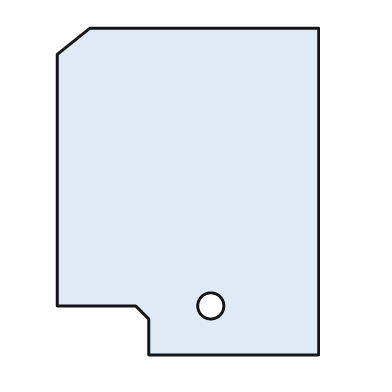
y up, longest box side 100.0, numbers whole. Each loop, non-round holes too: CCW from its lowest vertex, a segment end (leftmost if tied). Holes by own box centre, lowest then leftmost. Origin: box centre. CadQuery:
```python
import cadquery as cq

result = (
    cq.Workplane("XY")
    .moveTo(-12.0, -50.0)
    .lineTo(40.0, -50.0)
    .lineTo(40.0, 50.0)
    .lineTo(-30.0, 50.0)
    .lineTo(-40.0, 42.0)
    .lineTo(-40.0, -35.0)
    .lineTo(-16.0, -35.0)
    .lineTo(-12.0, -39.0)
    .close()
    .moveTo(7.0, -35.0)
    .circle(4.0)
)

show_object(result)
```